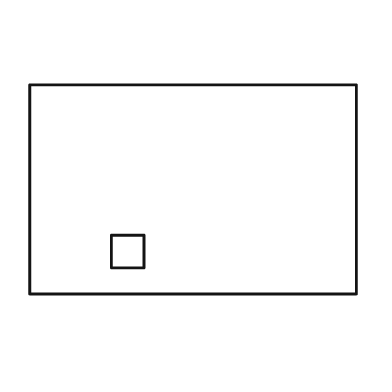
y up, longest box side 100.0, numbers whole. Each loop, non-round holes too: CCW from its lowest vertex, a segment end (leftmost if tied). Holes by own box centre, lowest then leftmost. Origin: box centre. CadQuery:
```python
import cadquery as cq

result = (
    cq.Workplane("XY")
    .moveTo(-50.0, -32.0)
    .lineTo(50.0, -32.0)
    .lineTo(50.0, 32.0)
    .lineTo(-50.0, 32.0)
    .close()
    .moveTo(-25.0, -24.0)
    .lineTo(-15.0, -24.0)
    .lineTo(-15.0, -14.0)
    .lineTo(-25.0, -14.0)
    .close()
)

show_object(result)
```